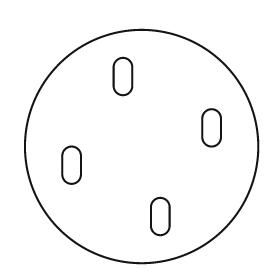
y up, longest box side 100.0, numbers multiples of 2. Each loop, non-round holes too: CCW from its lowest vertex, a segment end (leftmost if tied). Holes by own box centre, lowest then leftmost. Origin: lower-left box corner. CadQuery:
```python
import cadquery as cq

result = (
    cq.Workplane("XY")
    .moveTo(50.0, 50.0)
    .circle(50.0)
    .moveTo(54.0, 16.0)
    .threePointArc((58.0, 12.0), (62.0, 16.0))
    .lineTo(62.0, 24.0)
    .threePointArc((58.0, 28.0), (54.0, 24.0))
    .close()
    .moveTo(16.0, 38.0)
    .threePointArc((20.0, 34.0), (24.0, 38.0))
    .lineTo(24.0, 46.0)
    .threePointArc((20.0, 50.0), (16.0, 46.0))
    .close()
    .moveTo(76.0, 54.0)
    .threePointArc((80.0, 50.0), (84.0, 54.0))
    .lineTo(84.0, 62.0)
    .threePointArc((80.0, 66.0), (76.0, 62.0))
    .close()
    .moveTo(38.0, 76.0)
    .threePointArc((42.0, 72.0), (46.0, 76.0))
    .lineTo(46.0, 84.0)
    .threePointArc((42.0, 88.0), (38.0, 84.0))
    .close()
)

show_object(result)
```